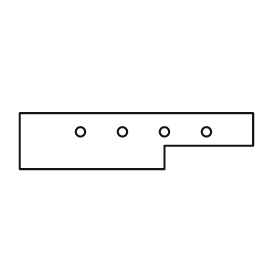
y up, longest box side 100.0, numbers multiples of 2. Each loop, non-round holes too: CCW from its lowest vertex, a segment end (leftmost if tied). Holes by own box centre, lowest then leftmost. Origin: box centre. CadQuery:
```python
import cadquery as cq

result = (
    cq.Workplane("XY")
    .moveTo(-50.0, -12.0)
    .lineTo(12.0, -12.0)
    .lineTo(12.0, -2.0)
    .lineTo(50.0, -2.0)
    .lineTo(50.0, 12.0)
    .lineTo(-50.0, 12.0)
    .close()
    .moveTo(-24.0, 4.0)
    .circle(2.0)
    .moveTo(-6.0, 4.0)
    .circle(2.0)
    .moveTo(12.0, 4.0)
    .circle(2.0)
    .moveTo(30.0, 4.0)
    .circle(2.0)
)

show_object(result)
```